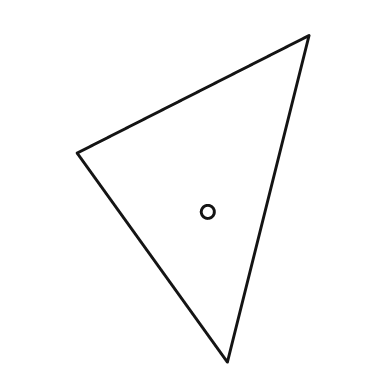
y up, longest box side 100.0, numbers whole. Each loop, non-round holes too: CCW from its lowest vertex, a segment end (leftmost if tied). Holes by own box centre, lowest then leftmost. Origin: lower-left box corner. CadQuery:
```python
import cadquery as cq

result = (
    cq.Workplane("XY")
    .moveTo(46.0, 0.0)
    .lineTo(71.0, 100.0)
    .lineTo(0.0, 64.0)
    .close()
    .moveTo(40.0, 46.0)
    .circle(2.0)
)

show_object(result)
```